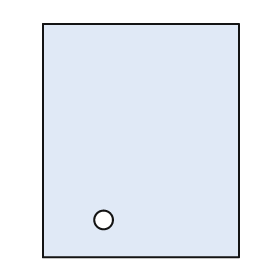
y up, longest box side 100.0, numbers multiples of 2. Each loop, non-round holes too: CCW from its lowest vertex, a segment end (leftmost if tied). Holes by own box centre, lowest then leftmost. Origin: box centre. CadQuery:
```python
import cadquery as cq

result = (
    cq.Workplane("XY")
    .moveTo(-42.0, -50.0)
    .lineTo(42.0, -50.0)
    .lineTo(42.0, 50.0)
    .lineTo(-42.0, 50.0)
    .close()
    .moveTo(-16.0, -34.0)
    .circle(4.0)
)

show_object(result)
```